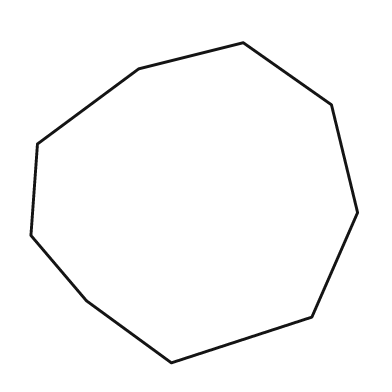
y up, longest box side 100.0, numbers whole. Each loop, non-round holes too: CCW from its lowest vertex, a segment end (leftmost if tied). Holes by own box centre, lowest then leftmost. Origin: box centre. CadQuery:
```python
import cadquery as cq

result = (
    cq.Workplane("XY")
    .moveTo(-7.0, -49.0)
    .lineTo(36.0, -35.0)
    .lineTo(50.0, -3.0)
    .lineTo(42.0, 30.0)
    .lineTo(15.0, 49.0)
    .lineTo(-17.0, 41.0)
    .lineTo(-48.0, 18.0)
    .lineTo(-50.0, -10.0)
    .lineTo(-33.0, -30.0)
    .close()
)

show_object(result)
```